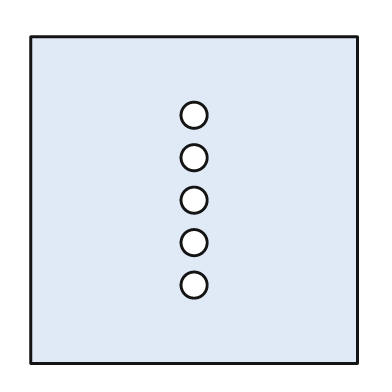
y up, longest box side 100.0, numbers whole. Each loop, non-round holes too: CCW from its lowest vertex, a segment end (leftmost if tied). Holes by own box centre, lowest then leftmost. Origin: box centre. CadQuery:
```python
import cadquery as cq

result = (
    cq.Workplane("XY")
    .moveTo(-50.0, -50.0)
    .lineTo(50.0, -50.0)
    .lineTo(50.0, 50.0)
    .lineTo(-50.0, 50.0)
    .close()
    .moveTo(0.0, -26.0)
    .circle(4.0)
    .moveTo(0.0, -13.0)
    .circle(4.0)
    .moveTo(0.0, 0.0)
    .circle(4.0)
    .moveTo(0.0, 13.0)
    .circle(4.0)
    .moveTo(0.0, 26.0)
    .circle(4.0)
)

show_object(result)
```